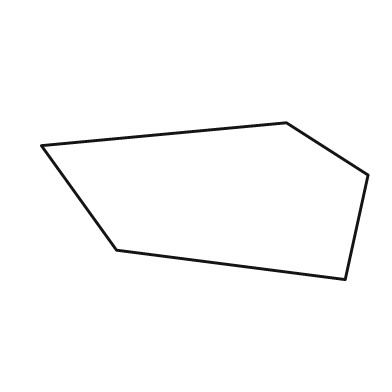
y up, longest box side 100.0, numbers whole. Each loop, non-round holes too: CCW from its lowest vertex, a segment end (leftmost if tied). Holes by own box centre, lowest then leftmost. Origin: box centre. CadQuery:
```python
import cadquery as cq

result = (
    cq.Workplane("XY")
    .moveTo(43.0, -24.0)
    .lineTo(50.0, 8.0)
    .lineTo(25.0, 24.0)
    .lineTo(-50.0, 17.0)
    .lineTo(-27.0, -15.0)
    .close()
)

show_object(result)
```